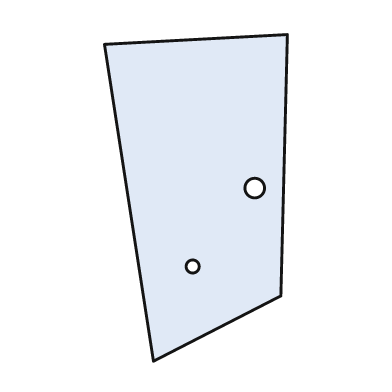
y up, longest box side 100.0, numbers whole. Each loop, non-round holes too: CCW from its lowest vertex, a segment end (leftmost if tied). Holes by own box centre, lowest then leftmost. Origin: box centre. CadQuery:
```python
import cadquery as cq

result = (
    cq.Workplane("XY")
    .moveTo(-13.0, -50.0)
    .lineTo(26.0, -30.0)
    .lineTo(28.0, 50.0)
    .lineTo(-28.0, 47.0)
    .close()
    .moveTo(-1.0, -21.0)
    .circle(2.0)
    .moveTo(18.0, 3.0)
    .circle(3.0)
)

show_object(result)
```